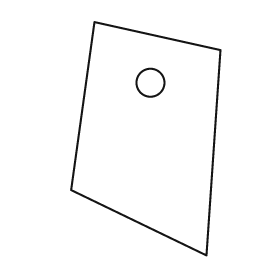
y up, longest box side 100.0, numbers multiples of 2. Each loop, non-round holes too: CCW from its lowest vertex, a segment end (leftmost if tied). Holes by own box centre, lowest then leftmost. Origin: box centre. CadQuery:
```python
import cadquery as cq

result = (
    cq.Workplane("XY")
    .moveTo(26.0, -50.0)
    .lineTo(32.0, 38.0)
    .lineTo(-22.0, 50.0)
    .lineTo(-32.0, -22.0)
    .close()
    .moveTo(2.0, 24.0)
    .circle(6.0)
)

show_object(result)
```